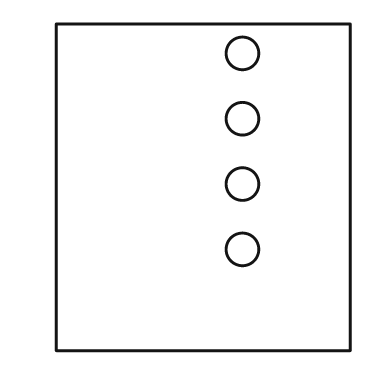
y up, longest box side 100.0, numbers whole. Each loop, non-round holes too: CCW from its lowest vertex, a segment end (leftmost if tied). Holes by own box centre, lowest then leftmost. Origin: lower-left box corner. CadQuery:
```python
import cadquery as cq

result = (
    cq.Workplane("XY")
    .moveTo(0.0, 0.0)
    .lineTo(90.0, 0.0)
    .lineTo(90.0, 100.0)
    .lineTo(0.0, 100.0)
    .close()
    .moveTo(57.0, 31.0)
    .circle(5.0)
    .moveTo(57.0, 51.0)
    .circle(5.0)
    .moveTo(57.0, 71.0)
    .circle(5.0)
    .moveTo(57.0, 91.0)
    .circle(5.0)
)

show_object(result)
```